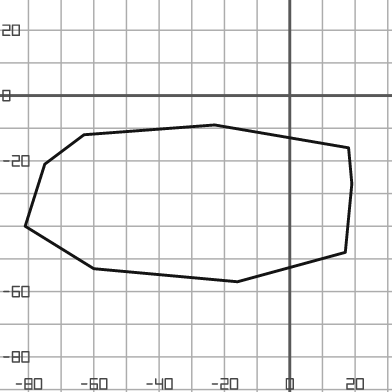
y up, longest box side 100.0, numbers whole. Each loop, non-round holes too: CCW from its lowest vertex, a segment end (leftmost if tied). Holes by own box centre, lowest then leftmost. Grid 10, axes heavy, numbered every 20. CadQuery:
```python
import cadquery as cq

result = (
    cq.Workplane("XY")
    .moveTo(-16.0, -57.0)
    .lineTo(17.0, -48.0)
    .lineTo(19.0, -27.0)
    .lineTo(18.0, -16.0)
    .lineTo(-23.0, -9.0)
    .lineTo(-63.0, -12.0)
    .lineTo(-75.0, -21.0)
    .lineTo(-81.0, -40.0)
    .lineTo(-60.0, -53.0)
    .close()
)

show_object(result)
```